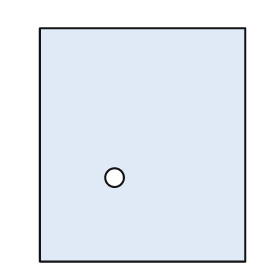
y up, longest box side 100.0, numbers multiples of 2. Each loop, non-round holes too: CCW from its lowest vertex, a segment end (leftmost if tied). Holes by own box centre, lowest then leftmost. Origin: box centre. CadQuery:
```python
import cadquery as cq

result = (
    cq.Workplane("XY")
    .moveTo(-44.0, -50.0)
    .lineTo(44.0, -50.0)
    .lineTo(44.0, 50.0)
    .lineTo(-44.0, 50.0)
    .close()
    .moveTo(-12.0, -14.0)
    .circle(4.0)
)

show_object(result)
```